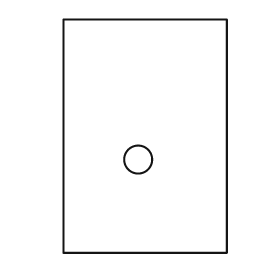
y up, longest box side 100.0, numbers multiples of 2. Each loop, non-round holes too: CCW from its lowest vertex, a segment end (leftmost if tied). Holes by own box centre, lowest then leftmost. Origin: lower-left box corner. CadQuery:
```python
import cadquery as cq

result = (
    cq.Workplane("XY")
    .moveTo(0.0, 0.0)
    .lineTo(70.0, 0.0)
    .lineTo(70.0, 100.0)
    .lineTo(0.0, 100.0)
    .close()
    .moveTo(32.0, 40.0)
    .circle(6.0)
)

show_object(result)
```